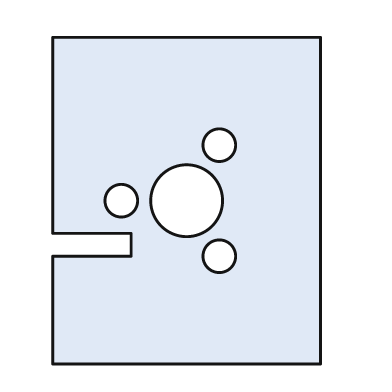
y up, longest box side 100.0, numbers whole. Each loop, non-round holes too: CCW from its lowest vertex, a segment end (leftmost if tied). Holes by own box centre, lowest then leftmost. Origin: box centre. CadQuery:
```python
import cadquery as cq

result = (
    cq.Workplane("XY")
    .moveTo(-41.0, -50.0)
    .lineTo(41.0, -50.0)
    .lineTo(41.0, 50.0)
    .lineTo(-41.0, 50.0)
    .lineTo(-41.0, -10.0)
    .lineTo(-17.0, -10.0)
    .lineTo(-17.0, -17.0)
    .lineTo(-41.0, -17.0)
    .close()
    .moveTo(10.0, -17.0)
    .circle(5.0)
    .moveTo(-20.0, 0.0)
    .circle(5.0)
    .moveTo(0.0, 0.0)
    .circle(11.0)
    .moveTo(10.0, 17.0)
    .circle(5.0)
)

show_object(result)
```